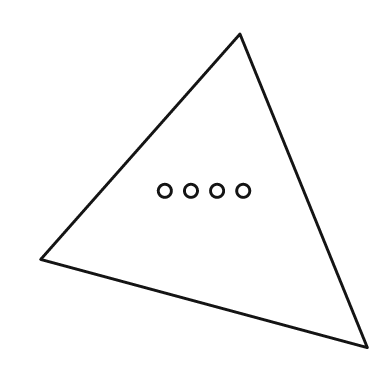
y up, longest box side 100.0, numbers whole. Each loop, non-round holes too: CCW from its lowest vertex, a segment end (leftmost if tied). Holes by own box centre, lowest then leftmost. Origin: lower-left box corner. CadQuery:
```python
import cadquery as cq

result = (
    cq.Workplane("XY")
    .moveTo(100.0, 0.0)
    .lineTo(61.0, 96.0)
    .lineTo(0.0, 27.0)
    .close()
    .moveTo(38.0, 48.0)
    .circle(2.0)
    .moveTo(46.0, 48.0)
    .circle(2.0)
    .moveTo(54.0, 48.0)
    .circle(2.0)
    .moveTo(62.0, 48.0)
    .circle(2.0)
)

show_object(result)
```